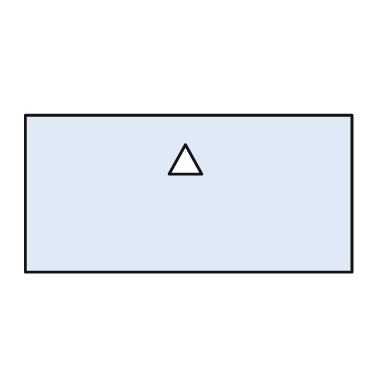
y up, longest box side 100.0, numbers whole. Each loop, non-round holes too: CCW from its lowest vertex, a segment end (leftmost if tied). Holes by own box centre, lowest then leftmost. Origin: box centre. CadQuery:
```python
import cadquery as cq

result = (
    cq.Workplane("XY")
    .moveTo(-50.0, -24.0)
    .lineTo(50.0, -24.0)
    .lineTo(50.0, 24.0)
    .lineTo(-50.0, 24.0)
    .close()
    .moveTo(-6.0, 6.0)
    .lineTo(4.0, 6.0)
    .lineTo(-1.0, 15.0)
    .close()
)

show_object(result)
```